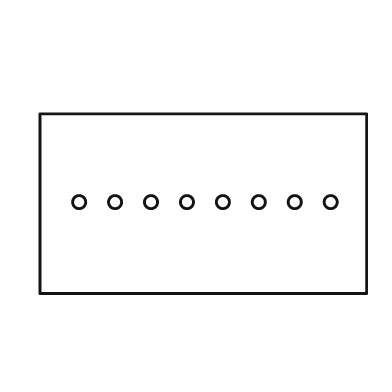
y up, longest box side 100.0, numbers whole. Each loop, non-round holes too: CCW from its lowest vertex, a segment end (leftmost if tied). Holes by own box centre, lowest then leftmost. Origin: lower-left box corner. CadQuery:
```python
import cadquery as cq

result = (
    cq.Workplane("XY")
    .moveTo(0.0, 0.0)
    .lineTo(100.0, 0.0)
    .lineTo(100.0, 55.0)
    .lineTo(0.0, 55.0)
    .close()
    .moveTo(12.0, 28.0)
    .circle(2.0)
    .moveTo(23.0, 28.0)
    .circle(2.0)
    .moveTo(34.0, 28.0)
    .circle(2.0)
    .moveTo(45.0, 28.0)
    .circle(2.0)
    .moveTo(56.0, 28.0)
    .circle(2.0)
    .moveTo(67.0, 28.0)
    .circle(2.0)
    .moveTo(78.0, 28.0)
    .circle(2.0)
    .moveTo(89.0, 28.0)
    .circle(2.0)
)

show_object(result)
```